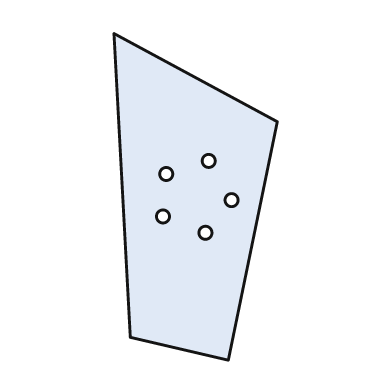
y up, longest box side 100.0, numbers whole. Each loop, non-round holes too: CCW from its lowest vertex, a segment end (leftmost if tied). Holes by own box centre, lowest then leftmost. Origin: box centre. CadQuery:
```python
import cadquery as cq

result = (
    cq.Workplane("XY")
    .moveTo(10.0, -50.0)
    .lineTo(25.0, 23.0)
    .lineTo(-25.0, 50.0)
    .lineTo(-20.0, -43.0)
    .close()
    .moveTo(3.0, -11.0)
    .circle(2.0)
    .moveTo(-10.0, -6.0)
    .circle(2.0)
    .moveTo(11.0, -1.0)
    .circle(2.0)
    .moveTo(-9.0, 7.0)
    .circle(2.0)
    .moveTo(4.0, 11.0)
    .circle(2.0)
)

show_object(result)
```